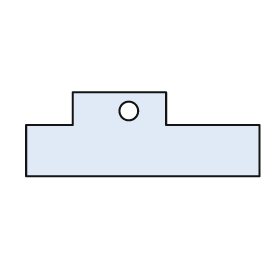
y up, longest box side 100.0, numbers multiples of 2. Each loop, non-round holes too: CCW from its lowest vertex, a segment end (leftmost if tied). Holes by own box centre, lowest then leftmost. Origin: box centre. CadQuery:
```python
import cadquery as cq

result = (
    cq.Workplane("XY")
    .moveTo(-50.0, -18.0)
    .lineTo(50.0, -18.0)
    .lineTo(50.0, 4.0)
    .lineTo(10.0, 4.0)
    .lineTo(10.0, 18.0)
    .lineTo(-30.0, 18.0)
    .lineTo(-30.0, 4.0)
    .lineTo(-50.0, 4.0)
    .close()
    .moveTo(-6.0, 10.0)
    .circle(4.0)
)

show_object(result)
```